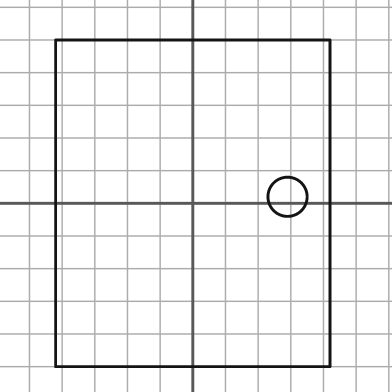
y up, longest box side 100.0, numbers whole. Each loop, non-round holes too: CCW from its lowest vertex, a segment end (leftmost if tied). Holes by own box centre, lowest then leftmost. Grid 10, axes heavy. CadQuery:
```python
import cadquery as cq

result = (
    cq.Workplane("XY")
    .moveTo(-42.0, -50.0)
    .lineTo(42.0, -50.0)
    .lineTo(42.0, 50.0)
    .lineTo(-42.0, 50.0)
    .close()
    .moveTo(29.0, 2.0)
    .circle(6.0)
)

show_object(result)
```